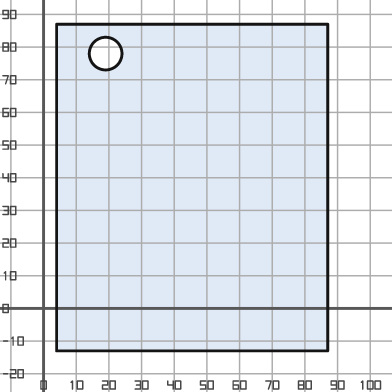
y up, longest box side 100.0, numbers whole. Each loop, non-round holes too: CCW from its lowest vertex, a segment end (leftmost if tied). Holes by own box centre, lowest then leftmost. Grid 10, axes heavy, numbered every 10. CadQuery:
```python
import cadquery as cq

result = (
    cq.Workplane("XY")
    .moveTo(4.0, -13.0)
    .lineTo(87.0, -13.0)
    .lineTo(87.0, 87.0)
    .lineTo(4.0, 87.0)
    .close()
    .moveTo(19.0, 78.0)
    .circle(5.0)
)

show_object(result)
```